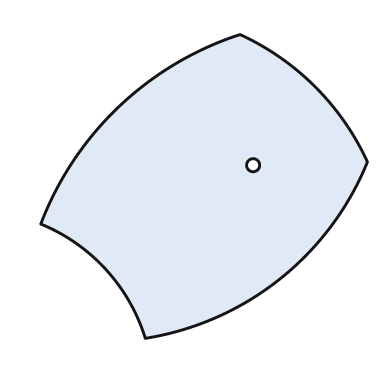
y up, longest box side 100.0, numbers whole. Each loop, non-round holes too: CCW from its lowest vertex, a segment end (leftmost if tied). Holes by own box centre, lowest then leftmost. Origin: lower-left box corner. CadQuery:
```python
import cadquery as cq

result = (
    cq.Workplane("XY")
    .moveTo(32.0, 0.0)
    .threePointArc((73.0, 18.0), (100.0, 54.0))
    .threePointArc((84.0, 77.0), (61.0, 93.0))
    .threePointArc((24.0, 71.0), (0.0, 35.0))
    .threePointArc((20.0, 21.0), (32.0, 0.0))
    .close()
    .moveTo(65.0, 53.0)
    .circle(2.0)
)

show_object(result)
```